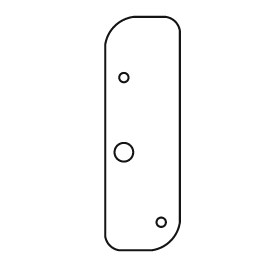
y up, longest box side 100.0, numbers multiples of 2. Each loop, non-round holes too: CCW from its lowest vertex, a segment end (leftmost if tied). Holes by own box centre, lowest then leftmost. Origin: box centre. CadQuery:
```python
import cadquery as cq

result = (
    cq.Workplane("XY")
    .moveTo(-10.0, -50.0)
    .lineTo(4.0, -50.0)
    .threePointArc((12.0, -46.0), (16.0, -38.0))
    .lineTo(16.0, 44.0)
    .threePointArc((14.0, 48.0), (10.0, 50.0))
    .lineTo(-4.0, 50.0)
    .threePointArc((-12.0, 46.0), (-16.0, 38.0))
    .lineTo(-16.0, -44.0)
    .threePointArc((-14.0, -48.0), (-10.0, -50.0))
    .close()
    .moveTo(8.0, -38.0)
    .circle(2.0)
    .moveTo(-8.0, -8.0)
    .circle(4.0)
    .moveTo(-8.0, 24.0)
    .circle(2.0)
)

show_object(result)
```